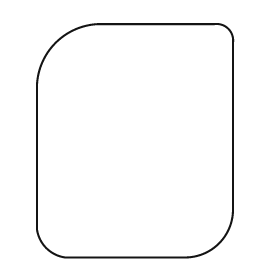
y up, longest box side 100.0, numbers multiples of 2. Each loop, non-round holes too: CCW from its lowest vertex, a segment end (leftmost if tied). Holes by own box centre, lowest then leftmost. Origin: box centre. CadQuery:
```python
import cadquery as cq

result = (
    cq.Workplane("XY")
    .moveTo(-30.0, -50.0)
    .lineTo(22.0, -50.0)
    .threePointArc((36.0, -44.0), (42.0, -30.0))
    .lineTo(42.0, 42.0)
    .threePointArc((40.0, 48.0), (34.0, 50.0))
    .lineTo(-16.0, 50.0)
    .threePointArc((-34.0, 42.0), (-42.0, 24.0))
    .lineTo(-42.0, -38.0)
    .threePointArc((-38.0, -46.0), (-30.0, -50.0))
    .close()
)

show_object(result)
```